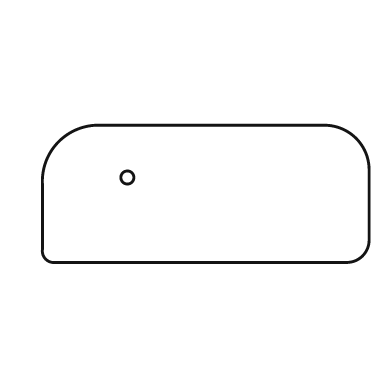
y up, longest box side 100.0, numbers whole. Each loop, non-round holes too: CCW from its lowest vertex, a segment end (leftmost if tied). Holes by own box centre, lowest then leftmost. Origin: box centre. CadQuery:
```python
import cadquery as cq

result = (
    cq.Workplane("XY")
    .moveTo(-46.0, -21.0)
    .lineTo(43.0, -21.0)
    .threePointArc((48.0, -19.0), (50.0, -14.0))
    .lineTo(50.0, 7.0)
    .threePointArc((46.0, 17.0), (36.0, 21.0))
    .lineTo(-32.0, 21.0)
    .threePointArc((-45.0, 16.0), (-50.0, 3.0))
    .lineTo(-50.0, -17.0)
    .threePointArc((-49.0, -20.0), (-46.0, -21.0))
    .close()
    .moveTo(-24.0, 5.0)
    .circle(2.0)
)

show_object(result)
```